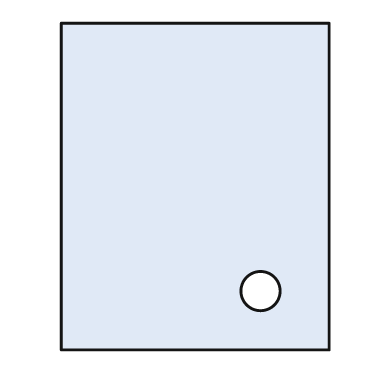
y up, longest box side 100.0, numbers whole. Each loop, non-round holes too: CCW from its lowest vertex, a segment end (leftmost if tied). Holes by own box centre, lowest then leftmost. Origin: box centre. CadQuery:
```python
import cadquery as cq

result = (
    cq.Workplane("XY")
    .moveTo(-41.0, -50.0)
    .lineTo(41.0, -50.0)
    .lineTo(41.0, 50.0)
    .lineTo(-41.0, 50.0)
    .close()
    .moveTo(20.0, -32.0)
    .circle(6.0)
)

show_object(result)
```